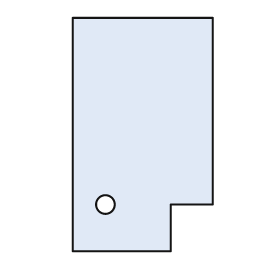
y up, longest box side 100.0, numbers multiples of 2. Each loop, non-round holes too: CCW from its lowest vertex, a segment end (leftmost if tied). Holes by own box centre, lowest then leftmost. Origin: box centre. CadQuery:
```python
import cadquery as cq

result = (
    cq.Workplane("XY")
    .moveTo(-30.0, -50.0)
    .lineTo(12.0, -50.0)
    .lineTo(12.0, -30.0)
    .lineTo(30.0, -30.0)
    .lineTo(30.0, 50.0)
    .lineTo(-30.0, 50.0)
    .close()
    .moveTo(-16.0, -30.0)
    .circle(4.0)
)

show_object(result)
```